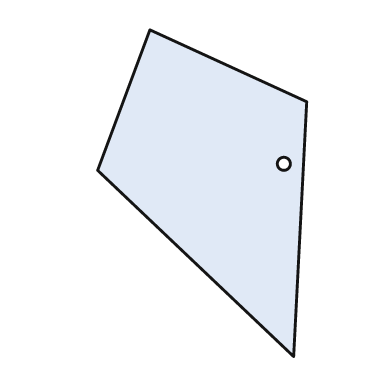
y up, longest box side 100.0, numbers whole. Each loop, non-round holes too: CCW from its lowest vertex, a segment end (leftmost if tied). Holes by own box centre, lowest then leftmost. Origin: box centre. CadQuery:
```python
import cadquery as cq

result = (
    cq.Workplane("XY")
    .moveTo(28.0, -50.0)
    .lineTo(32.0, 28.0)
    .lineTo(-16.0, 50.0)
    .lineTo(-32.0, 7.0)
    .close()
    .moveTo(25.0, 9.0)
    .circle(2.0)
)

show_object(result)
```